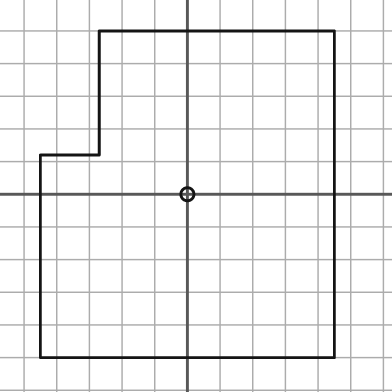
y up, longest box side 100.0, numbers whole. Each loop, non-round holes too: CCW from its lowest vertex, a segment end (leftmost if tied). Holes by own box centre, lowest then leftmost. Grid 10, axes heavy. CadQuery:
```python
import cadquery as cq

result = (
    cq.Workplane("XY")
    .moveTo(-45.0, -50.0)
    .lineTo(45.0, -50.0)
    .lineTo(45.0, 50.0)
    .lineTo(-27.0, 50.0)
    .lineTo(-27.0, 12.0)
    .lineTo(-45.0, 12.0)
    .close()
    .moveTo(0.0, 0.0)
    .circle(2.0)
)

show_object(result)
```